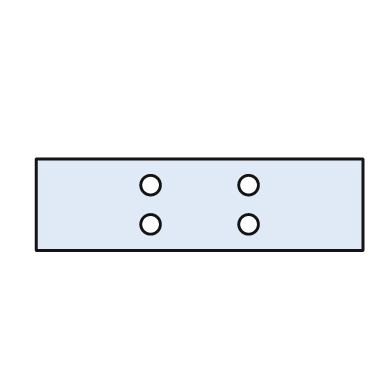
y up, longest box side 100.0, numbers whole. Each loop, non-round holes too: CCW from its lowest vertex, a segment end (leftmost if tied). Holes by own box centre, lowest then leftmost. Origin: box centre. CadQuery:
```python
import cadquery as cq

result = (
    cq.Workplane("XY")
    .moveTo(-50.0, -14.0)
    .lineTo(50.0, -14.0)
    .lineTo(50.0, 14.0)
    .lineTo(-50.0, 14.0)
    .close()
    .moveTo(-15.0, -6.0)
    .circle(3.0)
    .moveTo(15.0, -6.0)
    .circle(3.0)
    .moveTo(-15.0, 6.0)
    .circle(3.0)
    .moveTo(15.0, 6.0)
    .circle(3.0)
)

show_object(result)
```